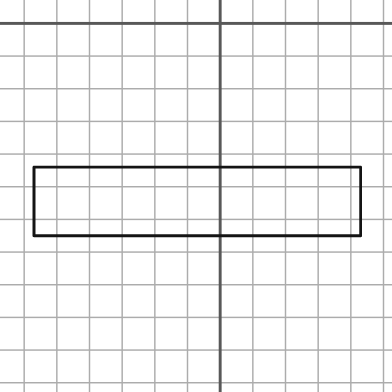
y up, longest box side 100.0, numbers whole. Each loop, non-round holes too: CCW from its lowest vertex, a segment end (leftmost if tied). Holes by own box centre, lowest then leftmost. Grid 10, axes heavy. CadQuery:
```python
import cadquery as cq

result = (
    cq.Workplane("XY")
    .moveTo(-57.0, -65.0)
    .lineTo(43.0, -65.0)
    .lineTo(43.0, -44.0)
    .lineTo(-57.0, -44.0)
    .close()
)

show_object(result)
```